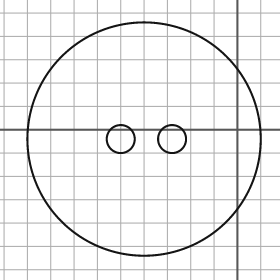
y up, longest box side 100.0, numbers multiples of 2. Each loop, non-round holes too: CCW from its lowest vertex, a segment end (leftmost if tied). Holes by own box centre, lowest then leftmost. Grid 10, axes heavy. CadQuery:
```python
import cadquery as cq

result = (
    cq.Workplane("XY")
    .moveTo(-40.0, -4.0)
    .circle(50.0)
    .moveTo(-50.0, -4.0)
    .circle(6.0)
    .moveTo(-28.0, -4.0)
    .circle(6.0)
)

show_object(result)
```